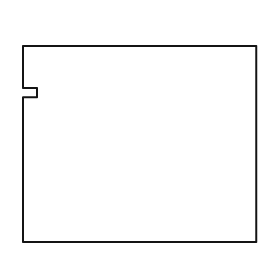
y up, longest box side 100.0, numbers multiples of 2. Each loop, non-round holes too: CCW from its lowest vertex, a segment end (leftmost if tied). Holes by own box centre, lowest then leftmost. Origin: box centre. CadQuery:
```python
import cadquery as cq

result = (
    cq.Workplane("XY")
    .moveTo(-50.0, -42.0)
    .lineTo(50.0, -42.0)
    .lineTo(50.0, 42.0)
    .lineTo(-50.0, 42.0)
    .lineTo(-50.0, 24.0)
    .lineTo(-44.0, 24.0)
    .lineTo(-44.0, 20.0)
    .lineTo(-50.0, 20.0)
    .close()
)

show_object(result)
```